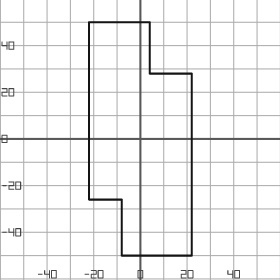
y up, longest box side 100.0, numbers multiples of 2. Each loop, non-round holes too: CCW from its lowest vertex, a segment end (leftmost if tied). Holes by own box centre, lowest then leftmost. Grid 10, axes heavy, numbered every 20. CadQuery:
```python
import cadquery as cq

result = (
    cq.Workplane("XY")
    .moveTo(-8.0, -50.0)
    .lineTo(22.0, -50.0)
    .lineTo(22.0, 28.0)
    .lineTo(4.0, 28.0)
    .lineTo(4.0, 50.0)
    .lineTo(-22.0, 50.0)
    .lineTo(-22.0, -26.0)
    .lineTo(-8.0, -26.0)
    .close()
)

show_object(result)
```